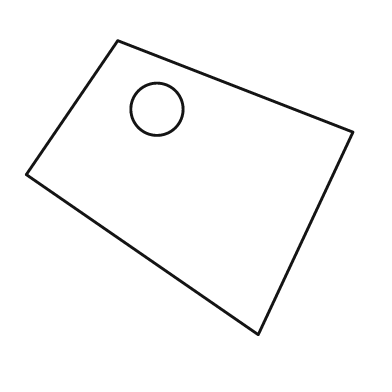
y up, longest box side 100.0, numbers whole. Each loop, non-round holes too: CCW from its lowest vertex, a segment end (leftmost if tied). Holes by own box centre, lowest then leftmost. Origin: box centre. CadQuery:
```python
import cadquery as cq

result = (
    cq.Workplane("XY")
    .moveTo(21.0, -45.0)
    .lineTo(50.0, 17.0)
    .lineTo(-22.0, 45.0)
    .lineTo(-50.0, 4.0)
    .close()
    .moveTo(-10.0, 24.0)
    .circle(8.0)
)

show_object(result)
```